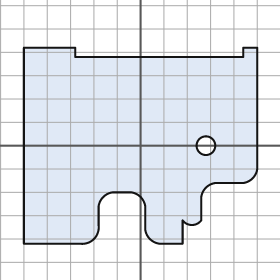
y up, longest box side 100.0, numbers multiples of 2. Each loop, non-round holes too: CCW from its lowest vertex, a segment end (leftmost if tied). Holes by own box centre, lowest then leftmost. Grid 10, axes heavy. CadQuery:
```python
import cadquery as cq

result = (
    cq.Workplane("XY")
    .moveTo(-50.0, -42.0)
    .lineTo(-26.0, -42.0)
    .threePointArc((-20.0, -40.0), (-18.0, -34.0))
    .lineTo(-18.0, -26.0)
    .threePointArc((-16.0, -22.0), (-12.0, -20.0))
    .lineTo(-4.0, -20.0)
    .threePointArc((0.0, -22.0), (2.0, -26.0))
    .lineTo(2.0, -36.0)
    .threePointArc((4.0, -40.0), (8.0, -42.0))
    .lineTo(18.0, -42.0)
    .lineTo(18.0, -32.0)
    .threePointArc((22.0, -34.0), (26.0, -32.0))
    .lineTo(26.0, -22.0)
    .threePointArc((28.0, -18.0), (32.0, -16.0))
    .lineTo(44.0, -16.0)
    .threePointArc((48.0, -14.0), (50.0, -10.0))
    .lineTo(50.0, 42.0)
    .lineTo(44.0, 42.0)
    .lineTo(44.0, 38.0)
    .lineTo(-28.0, 38.0)
    .lineTo(-28.0, 42.0)
    .lineTo(-50.0, 42.0)
    .close()
    .moveTo(28.0, 0.0)
    .circle(4.0)
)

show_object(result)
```